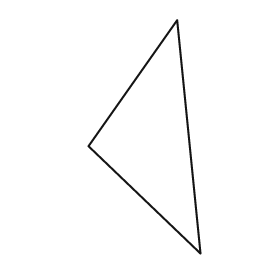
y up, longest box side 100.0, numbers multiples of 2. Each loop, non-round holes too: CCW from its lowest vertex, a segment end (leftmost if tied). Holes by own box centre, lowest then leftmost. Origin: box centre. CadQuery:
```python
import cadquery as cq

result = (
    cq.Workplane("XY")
    .moveTo(24.0, -50.0)
    .lineTo(14.0, 50.0)
    .lineTo(-24.0, -4.0)
    .close()
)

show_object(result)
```